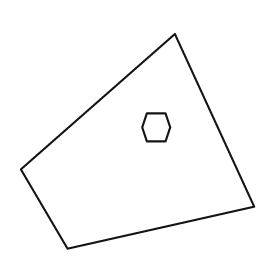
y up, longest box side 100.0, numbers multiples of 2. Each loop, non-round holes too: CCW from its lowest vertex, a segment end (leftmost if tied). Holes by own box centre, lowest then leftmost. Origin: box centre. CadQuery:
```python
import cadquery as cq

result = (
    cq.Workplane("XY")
    .moveTo(-30.0, -46.0)
    .lineTo(50.0, -28.0)
    .lineTo(16.0, 46.0)
    .lineTo(-50.0, -12.0)
    .close()
    .moveTo(4.0, 0.0)
    .lineTo(12.0, 0.0)
    .lineTo(14.0, 6.0)
    .lineTo(12.0, 12.0)
    .lineTo(4.0, 12.0)
    .lineTo(2.0, 6.0)
    .close()
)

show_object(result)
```